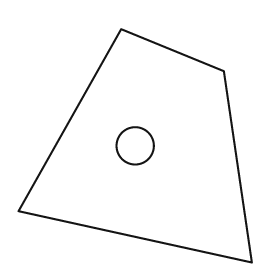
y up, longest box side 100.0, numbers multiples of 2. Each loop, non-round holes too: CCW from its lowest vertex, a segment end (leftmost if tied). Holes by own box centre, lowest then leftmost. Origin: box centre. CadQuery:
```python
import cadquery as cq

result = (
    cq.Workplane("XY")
    .moveTo(50.0, -50.0)
    .lineTo(38.0, 32.0)
    .lineTo(-6.0, 50.0)
    .lineTo(-50.0, -28.0)
    .close()
    .moveTo(0.0, 0.0)
    .circle(8.0)
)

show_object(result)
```